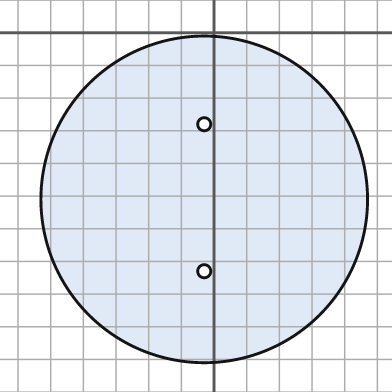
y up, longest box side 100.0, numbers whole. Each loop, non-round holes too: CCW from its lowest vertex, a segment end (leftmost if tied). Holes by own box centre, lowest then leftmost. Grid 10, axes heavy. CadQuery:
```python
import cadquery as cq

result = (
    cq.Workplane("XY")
    .moveTo(-3.0, -51.0)
    .circle(50.0)
    .moveTo(-3.0, -73.0)
    .circle(2.0)
    .moveTo(-3.0, -28.0)
    .circle(2.0)
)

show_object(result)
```